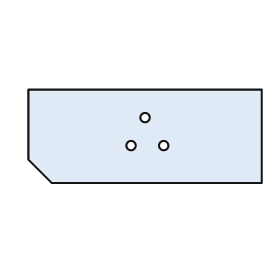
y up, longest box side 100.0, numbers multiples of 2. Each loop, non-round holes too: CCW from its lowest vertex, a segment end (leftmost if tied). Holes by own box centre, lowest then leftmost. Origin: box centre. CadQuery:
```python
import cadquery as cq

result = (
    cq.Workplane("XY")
    .moveTo(-40.0, -20.0)
    .lineTo(50.0, -20.0)
    .lineTo(50.0, 20.0)
    .lineTo(-50.0, 20.0)
    .lineTo(-50.0, -10.0)
    .close()
    .moveTo(-6.0, -4.0)
    .circle(2.0)
    .moveTo(8.0, -4.0)
    .circle(2.0)
    .moveTo(0.0, 8.0)
    .circle(2.0)
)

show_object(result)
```